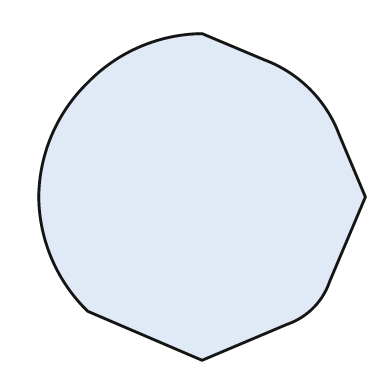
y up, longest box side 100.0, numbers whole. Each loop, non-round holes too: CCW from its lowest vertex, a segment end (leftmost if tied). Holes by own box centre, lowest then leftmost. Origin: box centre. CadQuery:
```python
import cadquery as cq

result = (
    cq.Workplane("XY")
    .moveTo(0.0, -50.0)
    .lineTo(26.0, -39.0)
    .threePointArc((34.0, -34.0), (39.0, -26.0))
    .lineTo(50.0, 0.0)
    .lineTo(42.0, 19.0)
    .threePointArc((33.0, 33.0), (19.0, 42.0))
    .lineTo(0.0, 50.0)
    .threePointArc((-19.0, 46.0), (-35.0, 35.0))
    .threePointArc((-46.0, 19.0), (-50.0, 0.0))
    .threePointArc((-46.0, -19.0), (-35.0, -35.0))
    .close()
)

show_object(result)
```